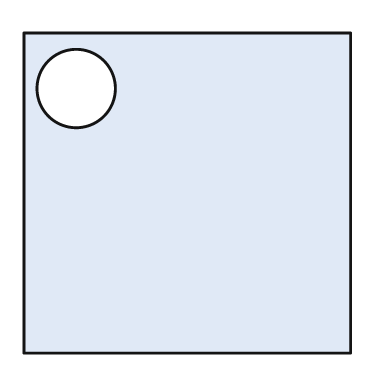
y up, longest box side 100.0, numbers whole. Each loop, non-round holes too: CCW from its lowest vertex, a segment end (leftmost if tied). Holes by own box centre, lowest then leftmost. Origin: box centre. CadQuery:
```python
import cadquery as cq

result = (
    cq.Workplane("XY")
    .moveTo(-50.0, -49.0)
    .lineTo(50.0, -49.0)
    .lineTo(50.0, 49.0)
    .lineTo(-50.0, 49.0)
    .close()
    .moveTo(-34.0, 32.0)
    .circle(12.0)
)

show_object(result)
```